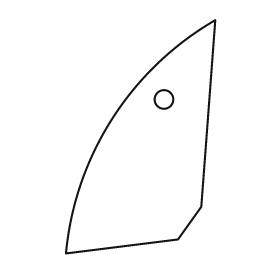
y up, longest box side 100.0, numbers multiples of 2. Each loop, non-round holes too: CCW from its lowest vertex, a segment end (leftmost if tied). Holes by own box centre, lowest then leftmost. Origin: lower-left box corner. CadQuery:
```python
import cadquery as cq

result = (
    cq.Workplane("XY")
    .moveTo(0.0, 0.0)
    .lineTo(48.0, 6.0)
    .lineTo(58.0, 20.0)
    .lineTo(64.0, 100.0)
    .threePointArc((20.0, 58.0), (0.0, 0.0))
    .close()
    .moveTo(42.0, 66.0)
    .circle(4.0)
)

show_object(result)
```